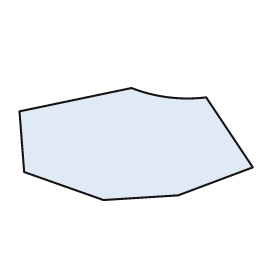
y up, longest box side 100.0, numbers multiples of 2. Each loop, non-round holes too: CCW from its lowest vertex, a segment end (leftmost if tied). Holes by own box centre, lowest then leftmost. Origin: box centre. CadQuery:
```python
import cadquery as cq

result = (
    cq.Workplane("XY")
    .moveTo(-14.0, -24.0)
    .lineTo(18.0, -22.0)
    .lineTo(50.0, -10.0)
    .lineTo(30.0, 20.0)
    .threePointArc((14.0, 20.0), (-2.0, 24.0))
    .lineTo(-50.0, 14.0)
    .lineTo(-48.0, -12.0)
    .close()
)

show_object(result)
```